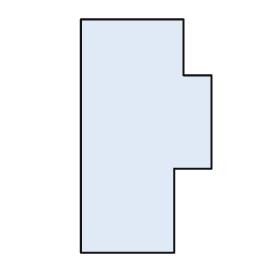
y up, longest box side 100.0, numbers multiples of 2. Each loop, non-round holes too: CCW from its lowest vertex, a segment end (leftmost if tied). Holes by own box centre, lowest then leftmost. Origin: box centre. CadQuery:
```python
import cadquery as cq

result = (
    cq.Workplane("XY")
    .moveTo(-28.0, -50.0)
    .lineTo(12.0, -50.0)
    .lineTo(12.0, -14.0)
    .lineTo(28.0, -14.0)
    .lineTo(28.0, 26.0)
    .lineTo(16.0, 26.0)
    .lineTo(16.0, 50.0)
    .lineTo(-28.0, 50.0)
    .close()
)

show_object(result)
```